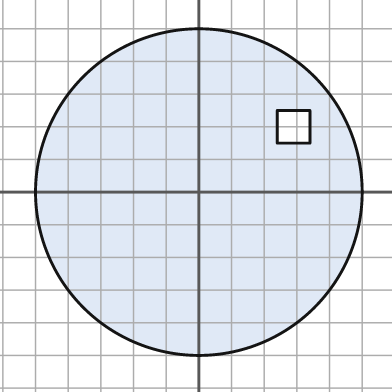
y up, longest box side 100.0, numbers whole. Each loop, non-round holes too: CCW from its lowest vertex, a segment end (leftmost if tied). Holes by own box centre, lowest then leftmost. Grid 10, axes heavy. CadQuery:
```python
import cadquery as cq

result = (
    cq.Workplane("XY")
    .moveTo(0.0, 0.0)
    .circle(50.0)
    .moveTo(24.0, 15.0)
    .lineTo(34.0, 15.0)
    .lineTo(34.0, 25.0)
    .lineTo(24.0, 25.0)
    .close()
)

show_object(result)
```